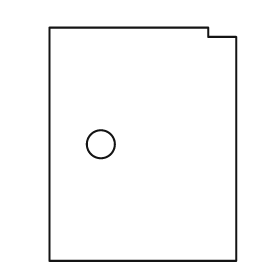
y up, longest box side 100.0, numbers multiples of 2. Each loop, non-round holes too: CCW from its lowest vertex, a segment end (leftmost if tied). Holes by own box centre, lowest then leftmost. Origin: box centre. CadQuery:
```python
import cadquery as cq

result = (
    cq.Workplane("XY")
    .moveTo(-40.0, -50.0)
    .lineTo(40.0, -50.0)
    .lineTo(40.0, 46.0)
    .lineTo(28.0, 46.0)
    .lineTo(28.0, 50.0)
    .lineTo(-40.0, 50.0)
    .close()
    .moveTo(-18.0, 0.0)
    .circle(6.0)
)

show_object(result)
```